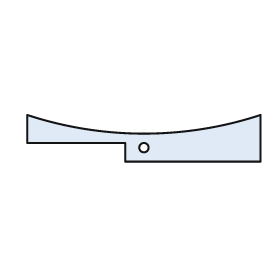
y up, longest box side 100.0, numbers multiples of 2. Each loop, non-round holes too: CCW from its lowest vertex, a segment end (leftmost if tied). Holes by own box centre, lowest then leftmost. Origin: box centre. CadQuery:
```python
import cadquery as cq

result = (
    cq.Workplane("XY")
    .moveTo(-8.0, -10.0)
    .lineTo(50.0, -10.0)
    .lineTo(50.0, 10.0)
    .threePointArc((0.0, 2.0), (-50.0, 10.0))
    .lineTo(-50.0, -2.0)
    .lineTo(-8.0, -2.0)
    .close()
    .moveTo(0.0, -4.0)
    .circle(2.0)
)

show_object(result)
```